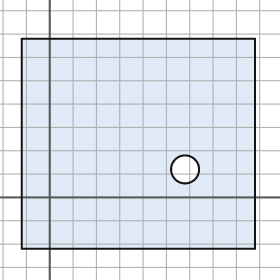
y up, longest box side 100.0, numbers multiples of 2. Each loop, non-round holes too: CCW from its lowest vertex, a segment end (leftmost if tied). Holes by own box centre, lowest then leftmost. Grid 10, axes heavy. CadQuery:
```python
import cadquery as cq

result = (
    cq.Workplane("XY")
    .moveTo(-12.0, -22.0)
    .lineTo(88.0, -22.0)
    .lineTo(88.0, 68.0)
    .lineTo(-12.0, 68.0)
    .close()
    .moveTo(58.0, 12.0)
    .circle(6.0)
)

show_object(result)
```